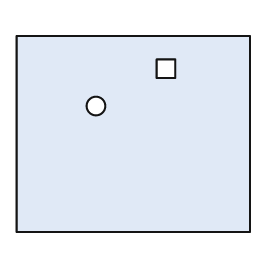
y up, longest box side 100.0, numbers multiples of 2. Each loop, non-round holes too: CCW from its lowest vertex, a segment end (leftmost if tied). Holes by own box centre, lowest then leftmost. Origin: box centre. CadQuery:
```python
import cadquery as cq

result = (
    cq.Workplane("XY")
    .moveTo(-50.0, -42.0)
    .lineTo(50.0, -42.0)
    .lineTo(50.0, 42.0)
    .lineTo(-50.0, 42.0)
    .close()
    .moveTo(-16.0, 12.0)
    .circle(4.0)
    .moveTo(10.0, 24.0)
    .lineTo(18.0, 24.0)
    .lineTo(18.0, 32.0)
    .lineTo(10.0, 32.0)
    .close()
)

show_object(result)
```